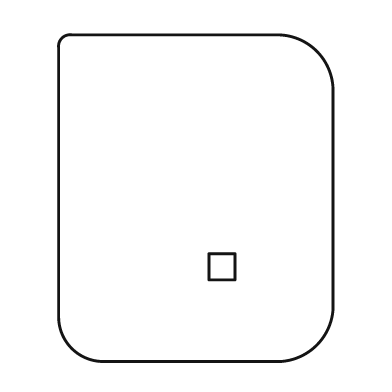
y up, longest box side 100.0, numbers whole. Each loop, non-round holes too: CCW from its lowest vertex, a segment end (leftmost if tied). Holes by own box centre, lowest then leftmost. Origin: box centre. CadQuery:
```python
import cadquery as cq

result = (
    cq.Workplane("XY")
    .moveTo(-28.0, -50.0)
    .lineTo(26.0, -50.0)
    .threePointArc((37.0, -45.0), (42.0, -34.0))
    .lineTo(42.0, 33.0)
    .threePointArc((37.0, 45.0), (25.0, 50.0))
    .lineTo(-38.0, 50.0)
    .threePointArc((-41.0, 49.0), (-42.0, 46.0))
    .lineTo(-42.0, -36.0)
    .threePointArc((-38.0, -46.0), (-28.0, -50.0))
    .close()
    .moveTo(4.0, -25.0)
    .lineTo(12.0, -25.0)
    .lineTo(12.0, -17.0)
    .lineTo(4.0, -17.0)
    .close()
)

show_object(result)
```